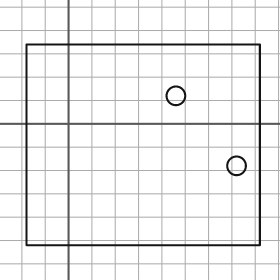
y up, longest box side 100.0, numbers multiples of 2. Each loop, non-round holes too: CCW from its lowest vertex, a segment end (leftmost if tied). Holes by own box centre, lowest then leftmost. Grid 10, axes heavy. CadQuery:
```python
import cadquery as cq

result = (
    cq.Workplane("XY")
    .moveTo(-18.0, -52.0)
    .lineTo(82.0, -52.0)
    .lineTo(82.0, 34.0)
    .lineTo(-18.0, 34.0)
    .close()
    .moveTo(72.0, -18.0)
    .circle(4.0)
    .moveTo(46.0, 12.0)
    .circle(4.0)
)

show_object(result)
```